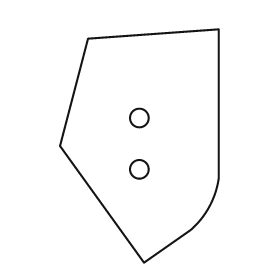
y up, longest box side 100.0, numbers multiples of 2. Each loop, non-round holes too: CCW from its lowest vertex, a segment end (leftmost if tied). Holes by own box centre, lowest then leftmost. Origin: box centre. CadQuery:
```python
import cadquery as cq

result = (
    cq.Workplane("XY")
    .moveTo(2.0, -50.0)
    .lineTo(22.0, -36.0)
    .threePointArc((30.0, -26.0), (34.0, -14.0))
    .lineTo(34.0, 50.0)
    .lineTo(-22.0, 46.0)
    .lineTo(-34.0, 0.0)
    .close()
    .moveTo(0.0, -10.0)
    .circle(4.0)
    .moveTo(0.0, 12.0)
    .circle(4.0)
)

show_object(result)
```